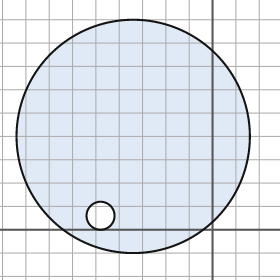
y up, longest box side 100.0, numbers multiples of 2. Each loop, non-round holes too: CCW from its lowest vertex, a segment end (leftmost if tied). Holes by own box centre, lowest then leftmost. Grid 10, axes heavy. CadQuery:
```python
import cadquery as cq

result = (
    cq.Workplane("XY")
    .moveTo(-34.0, 40.0)
    .circle(50.0)
    .moveTo(-48.0, 6.0)
    .circle(6.0)
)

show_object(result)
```